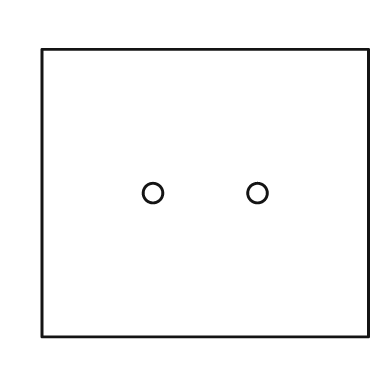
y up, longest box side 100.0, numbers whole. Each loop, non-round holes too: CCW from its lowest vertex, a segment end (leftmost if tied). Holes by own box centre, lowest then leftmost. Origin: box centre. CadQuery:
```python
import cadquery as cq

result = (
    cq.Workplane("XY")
    .moveTo(-50.0, -44.0)
    .lineTo(50.0, -44.0)
    .lineTo(50.0, 44.0)
    .lineTo(-50.0, 44.0)
    .close()
    .moveTo(-16.0, 0.0)
    .circle(3.0)
    .moveTo(16.0, 0.0)
    .circle(3.0)
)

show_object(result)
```